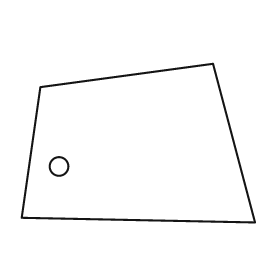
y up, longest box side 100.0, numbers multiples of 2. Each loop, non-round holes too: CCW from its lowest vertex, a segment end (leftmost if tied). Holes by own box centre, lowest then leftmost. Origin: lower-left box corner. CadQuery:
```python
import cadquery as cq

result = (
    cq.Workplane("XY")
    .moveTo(100.0, 0.0)
    .lineTo(82.0, 68.0)
    .lineTo(8.0, 58.0)
    .lineTo(0.0, 2.0)
    .close()
    .moveTo(16.0, 24.0)
    .circle(4.0)
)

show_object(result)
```